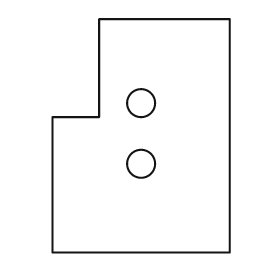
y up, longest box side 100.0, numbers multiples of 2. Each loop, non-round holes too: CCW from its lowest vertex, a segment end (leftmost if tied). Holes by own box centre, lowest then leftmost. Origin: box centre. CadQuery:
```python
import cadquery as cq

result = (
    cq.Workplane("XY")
    .moveTo(-38.0, -50.0)
    .lineTo(38.0, -50.0)
    .lineTo(38.0, 50.0)
    .lineTo(-18.0, 50.0)
    .lineTo(-18.0, 8.0)
    .lineTo(-38.0, 8.0)
    .close()
    .moveTo(0.0, -12.0)
    .circle(6.0)
    .moveTo(0.0, 14.0)
    .circle(6.0)
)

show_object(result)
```